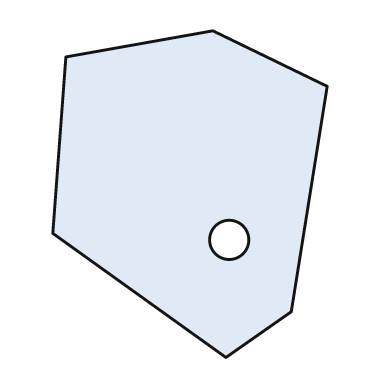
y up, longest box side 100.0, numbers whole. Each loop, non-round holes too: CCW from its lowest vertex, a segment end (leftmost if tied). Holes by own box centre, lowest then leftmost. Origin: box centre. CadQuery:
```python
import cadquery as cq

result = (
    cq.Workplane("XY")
    .moveTo(11.0, -50.0)
    .lineTo(31.0, -36.0)
    .lineTo(42.0, 33.0)
    .lineTo(7.0, 50.0)
    .lineTo(-38.0, 42.0)
    .lineTo(-42.0, -12.0)
    .close()
    .moveTo(12.0, -14.0)
    .circle(6.0)
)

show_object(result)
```